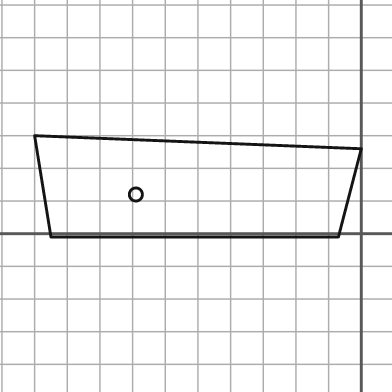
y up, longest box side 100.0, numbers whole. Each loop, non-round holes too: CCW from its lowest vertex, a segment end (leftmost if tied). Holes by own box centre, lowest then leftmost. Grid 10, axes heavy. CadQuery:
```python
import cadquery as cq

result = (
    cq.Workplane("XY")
    .moveTo(-95.0, -1.0)
    .lineTo(-7.0, -1.0)
    .lineTo(0.0, 26.0)
    .lineTo(-100.0, 30.0)
    .close()
    .moveTo(-69.0, 12.0)
    .circle(2.0)
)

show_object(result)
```